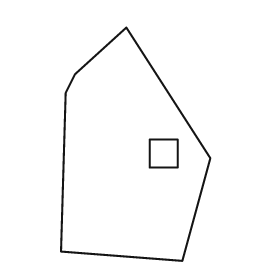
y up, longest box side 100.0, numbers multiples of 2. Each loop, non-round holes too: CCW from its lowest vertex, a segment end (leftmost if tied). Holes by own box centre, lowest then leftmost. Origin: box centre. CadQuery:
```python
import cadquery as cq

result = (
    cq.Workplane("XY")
    .moveTo(20.0, -50.0)
    .lineTo(32.0, -6.0)
    .lineTo(-4.0, 50.0)
    .lineTo(-26.0, 30.0)
    .lineTo(-30.0, 22.0)
    .lineTo(-32.0, -46.0)
    .close()
    .moveTo(6.0, -10.0)
    .lineTo(18.0, -10.0)
    .lineTo(18.0, 2.0)
    .lineTo(6.0, 2.0)
    .close()
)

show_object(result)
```